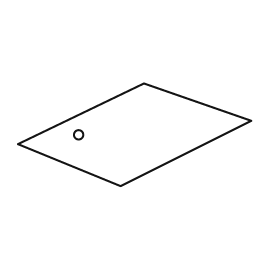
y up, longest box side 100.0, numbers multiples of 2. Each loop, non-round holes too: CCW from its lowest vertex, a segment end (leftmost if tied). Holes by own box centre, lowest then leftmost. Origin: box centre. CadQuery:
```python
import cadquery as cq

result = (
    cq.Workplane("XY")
    .moveTo(-6.0, -22.0)
    .lineTo(50.0, 6.0)
    .lineTo(4.0, 22.0)
    .lineTo(-50.0, -4.0)
    .close()
    .moveTo(-24.0, 0.0)
    .circle(2.0)
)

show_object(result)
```